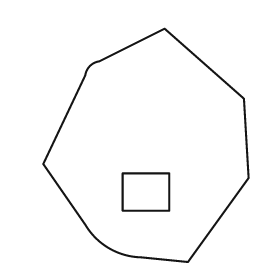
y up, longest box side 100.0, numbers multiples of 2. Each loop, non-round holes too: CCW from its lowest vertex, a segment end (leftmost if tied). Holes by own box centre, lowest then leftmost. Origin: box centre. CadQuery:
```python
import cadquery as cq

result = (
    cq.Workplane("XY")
    .moveTo(18.0, -50.0)
    .lineTo(44.0, -14.0)
    .lineTo(42.0, 20.0)
    .lineTo(8.0, 50.0)
    .lineTo(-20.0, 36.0)
    .threePointArc((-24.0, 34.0), (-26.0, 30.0))
    .lineTo(-44.0, -8.0)
    .lineTo(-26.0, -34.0)
    .threePointArc((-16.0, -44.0), (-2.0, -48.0))
    .close()
    .moveTo(-10.0, -28.0)
    .lineTo(10.0, -28.0)
    .lineTo(10.0, -12.0)
    .lineTo(-10.0, -12.0)
    .close()
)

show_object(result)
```